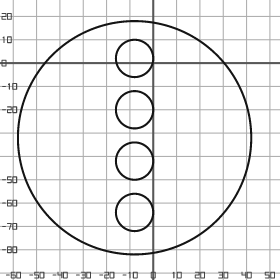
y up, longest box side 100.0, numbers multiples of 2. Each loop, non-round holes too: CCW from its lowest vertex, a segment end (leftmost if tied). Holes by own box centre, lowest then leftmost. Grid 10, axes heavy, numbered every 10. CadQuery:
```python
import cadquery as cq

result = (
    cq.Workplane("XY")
    .moveTo(-8.0, -32.0)
    .circle(50.0)
    .moveTo(-8.0, -64.0)
    .circle(8.0)
    .moveTo(-8.0, -42.0)
    .circle(8.0)
    .moveTo(-8.0, -20.0)
    .circle(8.0)
    .moveTo(-8.0, 2.0)
    .circle(8.0)
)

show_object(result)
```